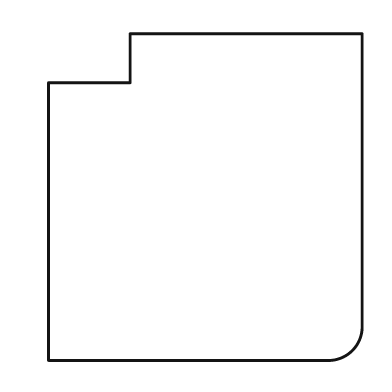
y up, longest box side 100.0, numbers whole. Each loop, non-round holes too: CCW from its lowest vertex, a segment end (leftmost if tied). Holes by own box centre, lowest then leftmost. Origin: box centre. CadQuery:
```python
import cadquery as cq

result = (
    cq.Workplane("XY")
    .moveTo(-48.0, -50.0)
    .lineTo(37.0, -50.0)
    .threePointArc((45.0, -47.0), (48.0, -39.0))
    .lineTo(48.0, 50.0)
    .lineTo(-23.0, 50.0)
    .lineTo(-23.0, 35.0)
    .lineTo(-48.0, 35.0)
    .close()
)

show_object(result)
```